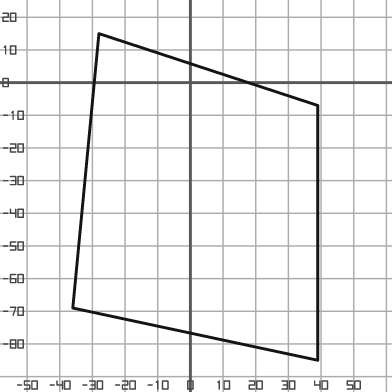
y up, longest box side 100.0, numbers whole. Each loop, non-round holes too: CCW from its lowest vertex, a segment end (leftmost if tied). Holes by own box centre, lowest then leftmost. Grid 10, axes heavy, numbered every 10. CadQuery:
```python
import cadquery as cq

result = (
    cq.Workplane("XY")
    .moveTo(39.0, -85.0)
    .lineTo(39.0, -7.0)
    .lineTo(-28.0, 15.0)
    .lineTo(-36.0, -69.0)
    .close()
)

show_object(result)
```